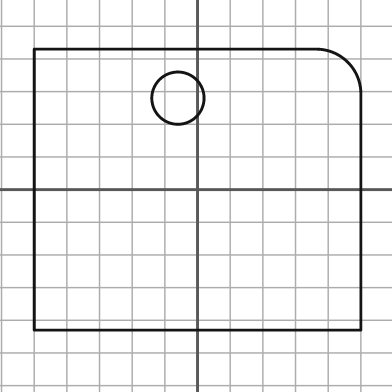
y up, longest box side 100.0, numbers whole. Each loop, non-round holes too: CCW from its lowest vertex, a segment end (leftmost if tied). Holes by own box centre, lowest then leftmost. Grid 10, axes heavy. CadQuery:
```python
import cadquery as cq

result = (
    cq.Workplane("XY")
    .moveTo(-50.0, -43.0)
    .lineTo(50.0, -43.0)
    .lineTo(50.0, 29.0)
    .threePointArc((46.0, 39.0), (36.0, 43.0))
    .lineTo(-50.0, 43.0)
    .close()
    .moveTo(-6.0, 28.0)
    .circle(8.0)
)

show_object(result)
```